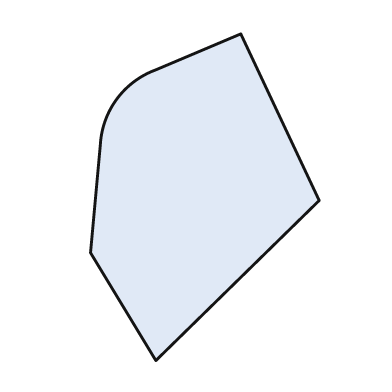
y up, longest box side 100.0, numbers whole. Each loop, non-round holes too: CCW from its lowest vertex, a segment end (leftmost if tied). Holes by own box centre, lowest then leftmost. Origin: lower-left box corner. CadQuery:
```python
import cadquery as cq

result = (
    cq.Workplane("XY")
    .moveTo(20.0, 0.0)
    .lineTo(70.0, 49.0)
    .lineTo(46.0, 100.0)
    .lineTo(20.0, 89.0)
    .threePointArc((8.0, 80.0), (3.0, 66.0))
    .lineTo(0.0, 33.0)
    .close()
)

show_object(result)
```